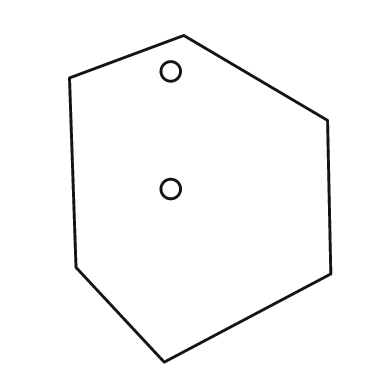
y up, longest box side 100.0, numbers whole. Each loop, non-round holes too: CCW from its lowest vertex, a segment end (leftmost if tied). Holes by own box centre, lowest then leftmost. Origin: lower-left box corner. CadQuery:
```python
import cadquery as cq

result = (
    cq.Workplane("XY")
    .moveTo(29.0, 0.0)
    .lineTo(80.0, 27.0)
    .lineTo(79.0, 74.0)
    .lineTo(35.0, 100.0)
    .lineTo(0.0, 87.0)
    .lineTo(2.0, 29.0)
    .close()
    .moveTo(31.0, 53.0)
    .circle(3.0)
    .moveTo(31.0, 89.0)
    .circle(3.0)
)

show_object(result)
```